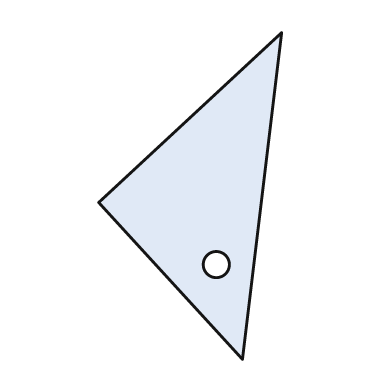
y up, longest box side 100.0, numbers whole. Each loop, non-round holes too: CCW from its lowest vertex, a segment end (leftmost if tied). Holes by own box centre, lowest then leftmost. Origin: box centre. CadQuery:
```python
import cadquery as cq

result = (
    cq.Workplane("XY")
    .moveTo(16.0, -50.0)
    .lineTo(28.0, 50.0)
    .lineTo(-28.0, -2.0)
    .close()
    .moveTo(8.0, -21.0)
    .circle(4.0)
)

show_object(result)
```